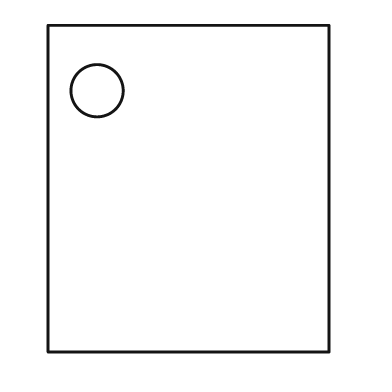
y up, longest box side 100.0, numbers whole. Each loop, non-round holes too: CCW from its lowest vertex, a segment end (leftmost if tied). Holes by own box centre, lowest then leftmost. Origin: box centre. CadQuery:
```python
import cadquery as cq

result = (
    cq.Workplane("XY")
    .moveTo(-43.0, -50.0)
    .lineTo(43.0, -50.0)
    .lineTo(43.0, 50.0)
    .lineTo(-43.0, 50.0)
    .close()
    .moveTo(-28.0, 30.0)
    .circle(8.0)
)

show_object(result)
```